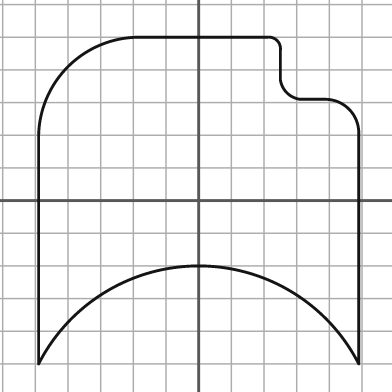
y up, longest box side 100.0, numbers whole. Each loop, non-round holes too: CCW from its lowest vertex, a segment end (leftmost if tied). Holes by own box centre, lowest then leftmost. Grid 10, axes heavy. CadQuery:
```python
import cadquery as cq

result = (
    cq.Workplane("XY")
    .moveTo(-49.0, -50.0)
    .threePointArc((0.0, -20.0), (49.0, -50.0))
    .lineTo(49.0, 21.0)
    .threePointArc((46.0, 28.0), (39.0, 31.0))
    .lineTo(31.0, 31.0)
    .threePointArc((27.0, 33.0), (25.0, 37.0))
    .lineTo(25.0, 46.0)
    .threePointArc((24.0, 49.0), (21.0, 50.0))
    .lineTo(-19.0, 50.0)
    .threePointArc((-40.0, 41.0), (-49.0, 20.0))
    .close()
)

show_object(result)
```